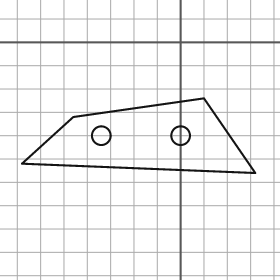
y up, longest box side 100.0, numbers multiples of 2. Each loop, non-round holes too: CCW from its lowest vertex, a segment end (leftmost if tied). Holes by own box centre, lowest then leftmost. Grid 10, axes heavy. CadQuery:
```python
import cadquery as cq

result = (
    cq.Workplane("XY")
    .moveTo(32.0, -56.0)
    .lineTo(10.0, -24.0)
    .lineTo(-46.0, -32.0)
    .lineTo(-68.0, -52.0)
    .close()
    .moveTo(-34.0, -40.0)
    .circle(4.0)
    .moveTo(0.0, -40.0)
    .circle(4.0)
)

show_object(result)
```